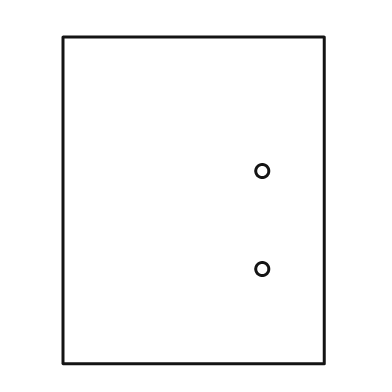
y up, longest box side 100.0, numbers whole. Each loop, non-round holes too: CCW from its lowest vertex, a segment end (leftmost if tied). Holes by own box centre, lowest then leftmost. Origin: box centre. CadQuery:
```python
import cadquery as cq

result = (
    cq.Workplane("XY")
    .moveTo(-40.0, -50.0)
    .lineTo(40.0, -50.0)
    .lineTo(40.0, 50.0)
    .lineTo(-40.0, 50.0)
    .close()
    .moveTo(21.0, -21.0)
    .circle(2.0)
    .moveTo(21.0, 9.0)
    .circle(2.0)
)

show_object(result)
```